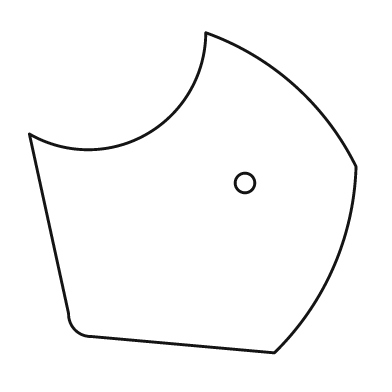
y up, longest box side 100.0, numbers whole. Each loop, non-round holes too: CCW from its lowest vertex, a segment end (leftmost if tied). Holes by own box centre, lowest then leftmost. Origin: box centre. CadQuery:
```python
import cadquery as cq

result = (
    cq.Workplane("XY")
    .moveTo(25.0, -49.0)
    .threePointArc((43.0, -23.0), (50.0, 8.0))
    .threePointArc((31.0, 33.0), (4.0, 49.0))
    .threePointArc((-14.0, 18.0), (-50.0, 18.0))
    .lineTo(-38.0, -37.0)
    .threePointArc((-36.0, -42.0), (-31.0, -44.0))
    .close()
    .moveTo(16.0, 3.0)
    .circle(3.0)
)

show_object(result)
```